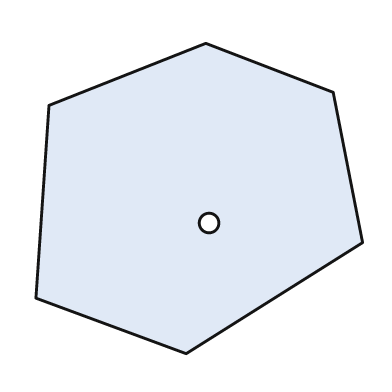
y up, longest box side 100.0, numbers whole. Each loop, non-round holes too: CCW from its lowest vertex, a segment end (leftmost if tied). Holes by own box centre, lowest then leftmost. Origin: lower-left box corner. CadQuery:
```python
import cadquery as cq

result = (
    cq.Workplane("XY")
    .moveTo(46.0, 0.0)
    .lineTo(100.0, 34.0)
    .lineTo(91.0, 80.0)
    .lineTo(52.0, 95.0)
    .lineTo(4.0, 76.0)
    .lineTo(0.0, 17.0)
    .close()
    .moveTo(53.0, 40.0)
    .circle(3.0)
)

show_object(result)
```